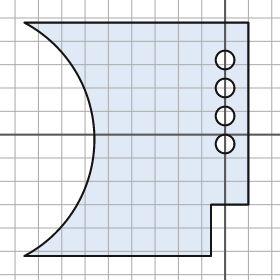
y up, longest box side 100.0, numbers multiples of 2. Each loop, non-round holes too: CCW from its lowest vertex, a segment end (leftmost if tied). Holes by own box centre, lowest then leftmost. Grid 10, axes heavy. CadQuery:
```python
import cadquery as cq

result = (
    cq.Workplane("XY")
    .moveTo(-86.0, -52.0)
    .lineTo(-6.0, -52.0)
    .lineTo(-6.0, -30.0)
    .lineTo(10.0, -30.0)
    .lineTo(10.0, 48.0)
    .lineTo(-86.0, 48.0)
    .threePointArc((-56.0, -2.0), (-86.0, -52.0))
    .close()
    .moveTo(0.0, -4.0)
    .circle(4.0)
    .moveTo(0.0, 8.0)
    .circle(4.0)
    .moveTo(0.0, 20.0)
    .circle(4.0)
    .moveTo(0.0, 32.0)
    .circle(4.0)
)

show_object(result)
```